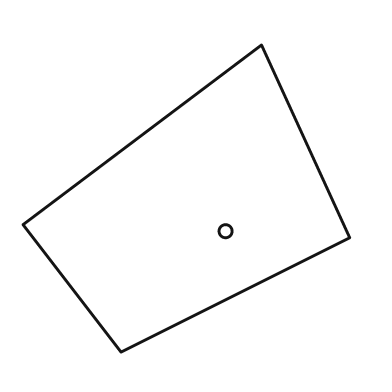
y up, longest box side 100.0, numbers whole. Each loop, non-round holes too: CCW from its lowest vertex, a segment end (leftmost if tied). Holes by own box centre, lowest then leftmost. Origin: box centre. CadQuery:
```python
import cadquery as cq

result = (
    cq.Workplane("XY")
    .moveTo(-20.0, -47.0)
    .lineTo(50.0, -12.0)
    .lineTo(23.0, 47.0)
    .lineTo(-50.0, -8.0)
    .close()
    .moveTo(12.0, -10.0)
    .circle(2.0)
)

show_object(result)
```